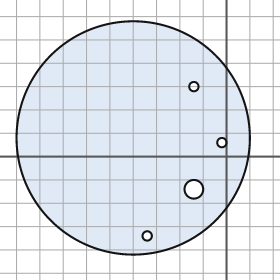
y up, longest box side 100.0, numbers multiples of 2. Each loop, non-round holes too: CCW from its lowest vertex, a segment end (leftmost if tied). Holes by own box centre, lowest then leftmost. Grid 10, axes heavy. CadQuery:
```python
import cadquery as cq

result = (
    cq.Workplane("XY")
    .moveTo(-40.0, 8.0)
    .circle(50.0)
    .moveTo(-34.0, -34.0)
    .circle(2.0)
    .moveTo(-14.0, -14.0)
    .circle(4.0)
    .moveTo(-2.0, 6.0)
    .circle(2.0)
    .moveTo(-14.0, 30.0)
    .circle(2.0)
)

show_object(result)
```